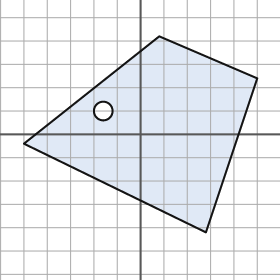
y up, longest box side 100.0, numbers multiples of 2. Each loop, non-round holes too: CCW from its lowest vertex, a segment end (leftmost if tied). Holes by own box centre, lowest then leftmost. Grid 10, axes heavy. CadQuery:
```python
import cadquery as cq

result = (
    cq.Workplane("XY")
    .moveTo(28.0, -42.0)
    .lineTo(50.0, 24.0)
    .lineTo(8.0, 42.0)
    .lineTo(-50.0, -4.0)
    .close()
    .moveTo(-16.0, 10.0)
    .circle(4.0)
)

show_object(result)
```